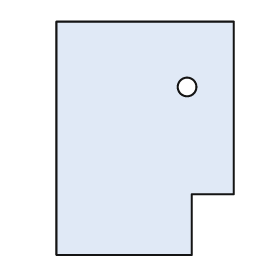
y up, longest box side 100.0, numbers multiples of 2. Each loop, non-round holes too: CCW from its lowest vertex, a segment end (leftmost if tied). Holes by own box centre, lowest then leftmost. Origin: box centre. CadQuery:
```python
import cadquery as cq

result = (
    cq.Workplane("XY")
    .moveTo(-38.0, -50.0)
    .lineTo(20.0, -50.0)
    .lineTo(20.0, -24.0)
    .lineTo(38.0, -24.0)
    .lineTo(38.0, 50.0)
    .lineTo(-38.0, 50.0)
    .close()
    .moveTo(18.0, 22.0)
    .circle(4.0)
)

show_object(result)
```